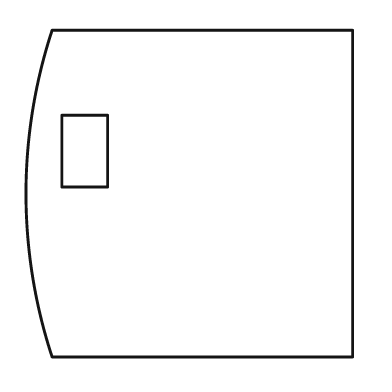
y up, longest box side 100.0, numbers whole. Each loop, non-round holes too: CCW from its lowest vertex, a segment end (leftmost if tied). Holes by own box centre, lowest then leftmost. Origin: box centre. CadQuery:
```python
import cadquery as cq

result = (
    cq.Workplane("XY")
    .moveTo(-42.0, -50.0)
    .lineTo(50.0, -50.0)
    .lineTo(50.0, 50.0)
    .lineTo(-42.0, 50.0)
    .threePointArc((-50.0, 0.0), (-42.0, -50.0))
    .close()
    .moveTo(-39.0, 2.0)
    .lineTo(-25.0, 2.0)
    .lineTo(-25.0, 24.0)
    .lineTo(-39.0, 24.0)
    .close()
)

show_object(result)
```